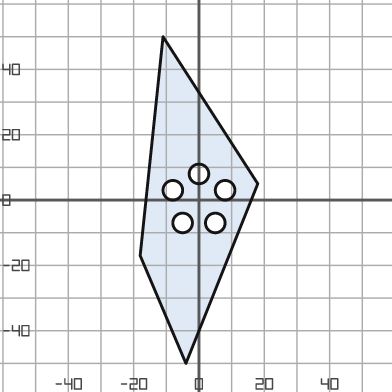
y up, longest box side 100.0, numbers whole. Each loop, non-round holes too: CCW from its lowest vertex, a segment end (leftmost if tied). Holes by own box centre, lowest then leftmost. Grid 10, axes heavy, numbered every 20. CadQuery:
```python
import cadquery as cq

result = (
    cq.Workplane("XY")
    .moveTo(-4.0, -50.0)
    .lineTo(18.0, 5.0)
    .lineTo(-11.0, 50.0)
    .lineTo(-18.0, -17.0)
    .close()
    .moveTo(-5.0, -7.0)
    .circle(3.0)
    .moveTo(5.0, -7.0)
    .circle(3.0)
    .moveTo(-8.0, 3.0)
    .circle(3.0)
    .moveTo(8.0, 3.0)
    .circle(3.0)
    .moveTo(0.0, 8.0)
    .circle(3.0)
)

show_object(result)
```